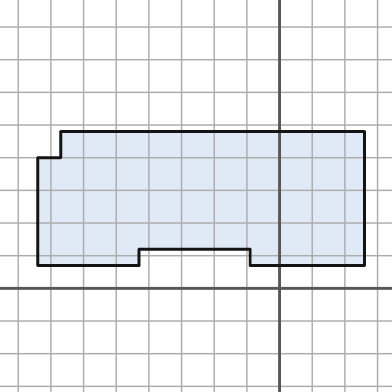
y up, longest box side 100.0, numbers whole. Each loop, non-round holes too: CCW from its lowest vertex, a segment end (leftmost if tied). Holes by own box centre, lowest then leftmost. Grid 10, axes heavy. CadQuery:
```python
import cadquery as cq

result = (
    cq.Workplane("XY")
    .moveTo(-74.0, 7.0)
    .lineTo(-43.0, 7.0)
    .lineTo(-43.0, 12.0)
    .lineTo(-9.0, 12.0)
    .lineTo(-9.0, 7.0)
    .lineTo(26.0, 7.0)
    .lineTo(26.0, 48.0)
    .lineTo(-67.0, 48.0)
    .lineTo(-67.0, 40.0)
    .lineTo(-74.0, 40.0)
    .close()
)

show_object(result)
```